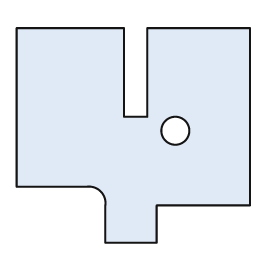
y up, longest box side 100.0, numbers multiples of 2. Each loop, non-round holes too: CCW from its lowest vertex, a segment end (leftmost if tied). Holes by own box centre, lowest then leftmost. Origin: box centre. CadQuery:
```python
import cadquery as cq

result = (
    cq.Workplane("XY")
    .moveTo(-12.0, -46.0)
    .lineTo(10.0, -46.0)
    .lineTo(10.0, -30.0)
    .lineTo(50.0, -30.0)
    .lineTo(50.0, 46.0)
    .lineTo(6.0, 46.0)
    .lineTo(6.0, 8.0)
    .lineTo(-4.0, 8.0)
    .lineTo(-4.0, 46.0)
    .lineTo(-50.0, 46.0)
    .lineTo(-50.0, -22.0)
    .lineTo(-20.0, -22.0)
    .threePointArc((-14.0, -24.0), (-12.0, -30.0))
    .close()
    .moveTo(18.0, 2.0)
    .circle(6.0)
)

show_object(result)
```